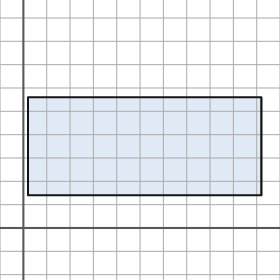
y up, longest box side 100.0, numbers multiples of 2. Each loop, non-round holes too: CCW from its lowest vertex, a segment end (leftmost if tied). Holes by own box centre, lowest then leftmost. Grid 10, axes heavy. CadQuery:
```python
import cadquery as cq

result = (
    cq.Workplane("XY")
    .moveTo(2.0, 14.0)
    .lineTo(102.0, 14.0)
    .lineTo(102.0, 56.0)
    .lineTo(2.0, 56.0)
    .close()
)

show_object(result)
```